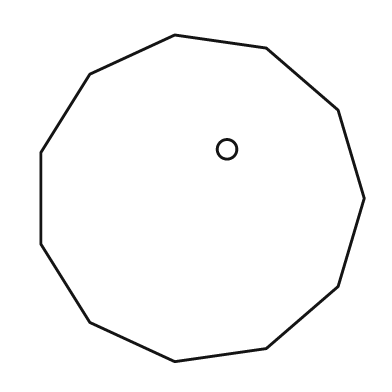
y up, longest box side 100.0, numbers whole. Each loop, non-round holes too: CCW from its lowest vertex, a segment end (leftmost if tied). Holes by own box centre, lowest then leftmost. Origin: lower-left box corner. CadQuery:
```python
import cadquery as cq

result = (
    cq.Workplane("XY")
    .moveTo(41.0, 0.0)
    .lineTo(69.0, 4.0)
    .lineTo(91.0, 23.0)
    .lineTo(99.0, 50.0)
    .lineTo(91.0, 77.0)
    .lineTo(69.0, 96.0)
    .lineTo(41.0, 100.0)
    .lineTo(15.0, 88.0)
    .lineTo(0.0, 64.0)
    .lineTo(0.0, 36.0)
    .lineTo(15.0, 12.0)
    .close()
    .moveTo(57.0, 65.0)
    .circle(3.0)
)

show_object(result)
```